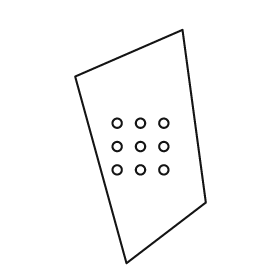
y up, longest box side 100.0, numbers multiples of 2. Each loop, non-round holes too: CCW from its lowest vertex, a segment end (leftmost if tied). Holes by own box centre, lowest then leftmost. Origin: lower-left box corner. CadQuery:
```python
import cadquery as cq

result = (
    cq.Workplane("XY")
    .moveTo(22.0, 0.0)
    .lineTo(56.0, 26.0)
    .lineTo(46.0, 100.0)
    .lineTo(0.0, 80.0)
    .close()
    .moveTo(18.0, 40.0)
    .circle(2.0)
    .moveTo(28.0, 40.0)
    .circle(2.0)
    .moveTo(38.0, 40.0)
    .circle(2.0)
    .moveTo(18.0, 50.0)
    .circle(2.0)
    .moveTo(28.0, 50.0)
    .circle(2.0)
    .moveTo(38.0, 50.0)
    .circle(2.0)
    .moveTo(18.0, 60.0)
    .circle(2.0)
    .moveTo(28.0, 60.0)
    .circle(2.0)
    .moveTo(38.0, 60.0)
    .circle(2.0)
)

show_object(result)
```